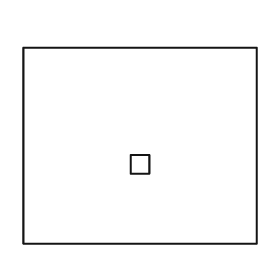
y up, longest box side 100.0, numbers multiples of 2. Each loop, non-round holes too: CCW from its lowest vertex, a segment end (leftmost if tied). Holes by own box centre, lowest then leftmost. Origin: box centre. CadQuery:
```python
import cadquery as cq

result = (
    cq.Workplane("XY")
    .moveTo(-50.0, -42.0)
    .lineTo(50.0, -42.0)
    .lineTo(50.0, 42.0)
    .lineTo(-50.0, 42.0)
    .close()
    .moveTo(-4.0, -12.0)
    .lineTo(4.0, -12.0)
    .lineTo(4.0, -4.0)
    .lineTo(-4.0, -4.0)
    .close()
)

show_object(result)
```